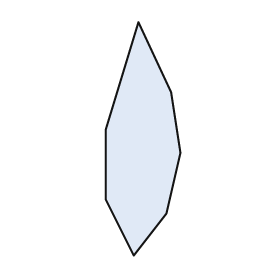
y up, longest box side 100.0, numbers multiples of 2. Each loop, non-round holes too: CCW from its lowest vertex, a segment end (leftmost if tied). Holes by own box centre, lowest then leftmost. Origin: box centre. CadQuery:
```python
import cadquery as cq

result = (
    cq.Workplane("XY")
    .moveTo(-4.0, -50.0)
    .lineTo(10.0, -32.0)
    .lineTo(16.0, -6.0)
    .lineTo(12.0, 20.0)
    .lineTo(-2.0, 50.0)
    .lineTo(-16.0, 4.0)
    .lineTo(-16.0, -26.0)
    .close()
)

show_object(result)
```